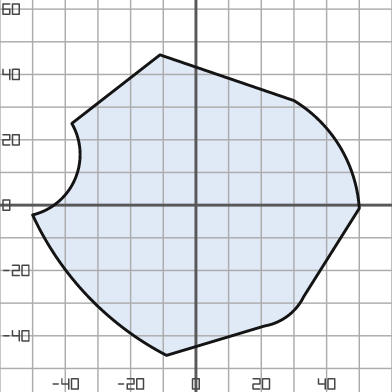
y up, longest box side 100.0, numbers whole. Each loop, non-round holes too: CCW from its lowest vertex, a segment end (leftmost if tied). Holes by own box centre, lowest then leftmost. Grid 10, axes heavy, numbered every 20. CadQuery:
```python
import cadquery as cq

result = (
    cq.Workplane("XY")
    .moveTo(-9.0, -46.0)
    .lineTo(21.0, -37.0)
    .threePointArc((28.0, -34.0), (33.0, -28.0))
    .lineTo(50.0, -1.0)
    .threePointArc((44.0, 18.0), (30.0, 32.0))
    .lineTo(-11.0, 46.0)
    .lineTo(-38.0, 25.0)
    .threePointArc((-37.0, 8.0), (-50.0, -3.0))
    .threePointArc((-33.0, -28.0), (-9.0, -46.0))
    .close()
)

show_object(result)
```